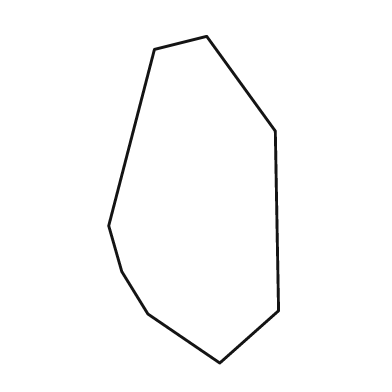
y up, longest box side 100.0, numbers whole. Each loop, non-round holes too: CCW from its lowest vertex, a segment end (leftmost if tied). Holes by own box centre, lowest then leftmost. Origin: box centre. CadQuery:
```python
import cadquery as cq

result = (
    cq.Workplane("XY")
    .moveTo(8.0, -50.0)
    .lineTo(26.0, -34.0)
    .lineTo(25.0, 21.0)
    .lineTo(4.0, 50.0)
    .lineTo(-12.0, 46.0)
    .lineTo(-26.0, -8.0)
    .lineTo(-22.0, -22.0)
    .lineTo(-14.0, -35.0)
    .close()
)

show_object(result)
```